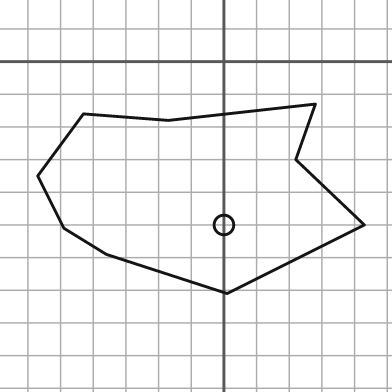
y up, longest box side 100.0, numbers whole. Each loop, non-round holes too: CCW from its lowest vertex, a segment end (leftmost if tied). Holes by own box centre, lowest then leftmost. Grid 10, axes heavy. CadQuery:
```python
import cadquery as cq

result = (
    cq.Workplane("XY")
    .moveTo(1.0, -71.0)
    .lineTo(43.0, -50.0)
    .lineTo(22.0, -30.0)
    .lineTo(28.0, -13.0)
    .lineTo(-17.0, -18.0)
    .lineTo(-43.0, -16.0)
    .lineTo(-57.0, -35.0)
    .lineTo(-49.0, -51.0)
    .lineTo(-36.0, -59.0)
    .close()
    .moveTo(0.0, -50.0)
    .circle(3.0)
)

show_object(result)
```